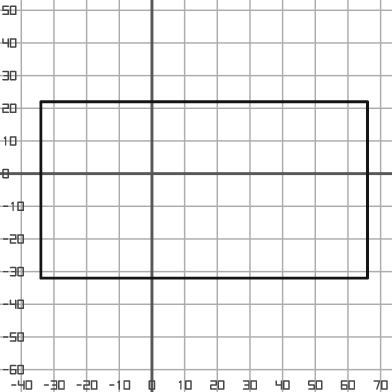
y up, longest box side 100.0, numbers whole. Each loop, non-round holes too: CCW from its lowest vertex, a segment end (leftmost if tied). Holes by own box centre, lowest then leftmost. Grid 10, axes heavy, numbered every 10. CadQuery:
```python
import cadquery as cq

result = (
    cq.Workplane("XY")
    .moveTo(-34.0, -32.0)
    .lineTo(66.0, -32.0)
    .lineTo(66.0, 22.0)
    .lineTo(-34.0, 22.0)
    .close()
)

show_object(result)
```